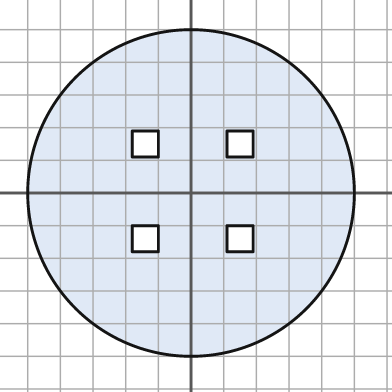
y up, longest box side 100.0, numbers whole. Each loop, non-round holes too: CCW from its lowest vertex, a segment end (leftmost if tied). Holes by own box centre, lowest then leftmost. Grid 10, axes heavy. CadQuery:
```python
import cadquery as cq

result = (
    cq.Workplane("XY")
    .moveTo(0.0, 0.0)
    .circle(50.0)
    .moveTo(-18.0, -18.0)
    .lineTo(-10.0, -18.0)
    .lineTo(-10.0, -10.0)
    .lineTo(-18.0, -10.0)
    .close()
    .moveTo(11.0, -18.0)
    .lineTo(19.0, -18.0)
    .lineTo(19.0, -10.0)
    .lineTo(11.0, -10.0)
    .close()
    .moveTo(-18.0, 11.0)
    .lineTo(-10.0, 11.0)
    .lineTo(-10.0, 19.0)
    .lineTo(-18.0, 19.0)
    .close()
    .moveTo(11.0, 11.0)
    .lineTo(19.0, 11.0)
    .lineTo(19.0, 19.0)
    .lineTo(11.0, 19.0)
    .close()
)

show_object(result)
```